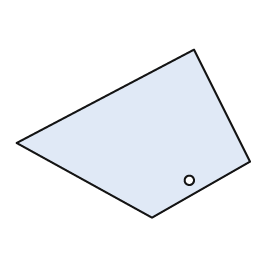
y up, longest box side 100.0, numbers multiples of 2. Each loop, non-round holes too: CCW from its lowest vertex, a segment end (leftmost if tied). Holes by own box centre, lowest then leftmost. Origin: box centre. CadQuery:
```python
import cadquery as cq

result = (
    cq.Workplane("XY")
    .moveTo(8.0, -36.0)
    .lineTo(50.0, -12.0)
    .lineTo(26.0, 36.0)
    .lineTo(-50.0, -4.0)
    .close()
    .moveTo(24.0, -20.0)
    .circle(2.0)
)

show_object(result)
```